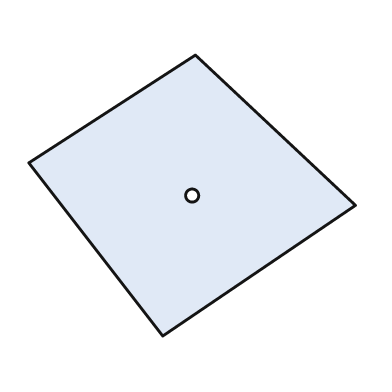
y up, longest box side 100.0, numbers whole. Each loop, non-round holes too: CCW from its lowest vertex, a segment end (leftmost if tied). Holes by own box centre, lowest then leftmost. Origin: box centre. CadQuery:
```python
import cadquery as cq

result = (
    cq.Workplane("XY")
    .moveTo(-9.0, -43.0)
    .lineTo(50.0, -3.0)
    .lineTo(1.0, 43.0)
    .lineTo(-50.0, 10.0)
    .close()
    .moveTo(0.0, 0.0)
    .circle(2.0)
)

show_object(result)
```